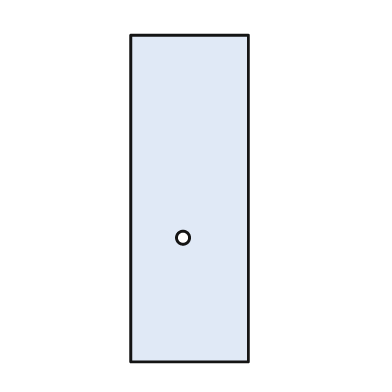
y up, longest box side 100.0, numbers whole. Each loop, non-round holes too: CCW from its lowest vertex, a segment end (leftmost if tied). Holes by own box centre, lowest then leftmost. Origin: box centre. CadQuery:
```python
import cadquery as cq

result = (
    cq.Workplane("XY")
    .moveTo(-18.0, -50.0)
    .lineTo(18.0, -50.0)
    .lineTo(18.0, 50.0)
    .lineTo(-18.0, 50.0)
    .close()
    .moveTo(-2.0, -12.0)
    .circle(2.0)
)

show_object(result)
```